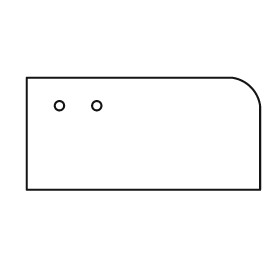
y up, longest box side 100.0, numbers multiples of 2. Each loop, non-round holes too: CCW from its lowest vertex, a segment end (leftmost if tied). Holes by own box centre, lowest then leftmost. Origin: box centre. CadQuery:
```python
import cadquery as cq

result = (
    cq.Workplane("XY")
    .moveTo(-50.0, -24.0)
    .lineTo(50.0, -24.0)
    .lineTo(50.0, 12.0)
    .threePointArc((46.0, 20.0), (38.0, 24.0))
    .lineTo(-50.0, 24.0)
    .close()
    .moveTo(-36.0, 12.0)
    .circle(2.0)
    .moveTo(-20.0, 12.0)
    .circle(2.0)
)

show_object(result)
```